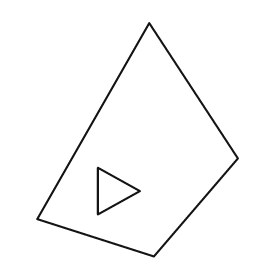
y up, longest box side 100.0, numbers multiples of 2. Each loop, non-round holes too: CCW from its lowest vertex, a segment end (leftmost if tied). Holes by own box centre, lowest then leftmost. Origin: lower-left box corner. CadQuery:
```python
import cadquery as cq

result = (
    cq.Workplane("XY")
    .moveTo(50.0, 0.0)
    .lineTo(86.0, 42.0)
    .lineTo(48.0, 100.0)
    .lineTo(0.0, 16.0)
    .close()
    .moveTo(26.0, 18.0)
    .lineTo(44.0, 28.0)
    .lineTo(26.0, 38.0)
    .close()
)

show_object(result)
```